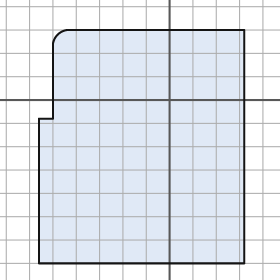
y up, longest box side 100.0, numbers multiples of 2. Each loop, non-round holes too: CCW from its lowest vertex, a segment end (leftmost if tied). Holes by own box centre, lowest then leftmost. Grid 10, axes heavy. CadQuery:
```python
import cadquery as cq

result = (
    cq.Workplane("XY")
    .moveTo(-56.0, -70.0)
    .lineTo(32.0, -70.0)
    .lineTo(32.0, 30.0)
    .lineTo(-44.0, 30.0)
    .threePointArc((-48.0, 28.0), (-50.0, 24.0))
    .lineTo(-50.0, -8.0)
    .lineTo(-56.0, -8.0)
    .close()
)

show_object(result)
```